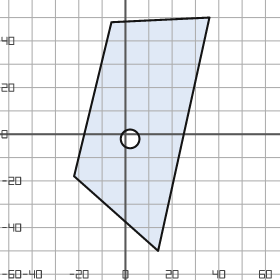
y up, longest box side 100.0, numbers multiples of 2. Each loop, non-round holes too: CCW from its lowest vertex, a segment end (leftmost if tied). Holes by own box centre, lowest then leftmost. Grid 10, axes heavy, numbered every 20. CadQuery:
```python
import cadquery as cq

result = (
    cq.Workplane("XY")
    .moveTo(14.0, -50.0)
    .lineTo(36.0, 50.0)
    .lineTo(-6.0, 48.0)
    .lineTo(-22.0, -18.0)
    .close()
    .moveTo(2.0, -2.0)
    .circle(4.0)
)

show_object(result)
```